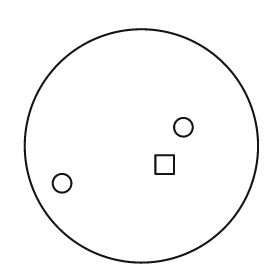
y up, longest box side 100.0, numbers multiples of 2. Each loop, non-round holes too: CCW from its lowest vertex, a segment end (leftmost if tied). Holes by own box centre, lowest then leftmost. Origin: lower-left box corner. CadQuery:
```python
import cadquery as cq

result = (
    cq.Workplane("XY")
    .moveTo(50.0, 50.0)
    .circle(50.0)
    .moveTo(16.0, 34.0)
    .circle(4.0)
    .moveTo(56.0, 38.0)
    .lineTo(64.0, 38.0)
    .lineTo(64.0, 46.0)
    .lineTo(56.0, 46.0)
    .close()
    .moveTo(68.0, 58.0)
    .circle(4.0)
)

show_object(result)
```